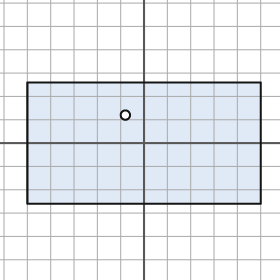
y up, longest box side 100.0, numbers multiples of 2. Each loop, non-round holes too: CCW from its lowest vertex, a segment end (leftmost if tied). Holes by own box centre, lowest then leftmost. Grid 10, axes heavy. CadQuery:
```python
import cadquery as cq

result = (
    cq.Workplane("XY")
    .moveTo(-50.0, -26.0)
    .lineTo(50.0, -26.0)
    .lineTo(50.0, 26.0)
    .lineTo(-50.0, 26.0)
    .close()
    .moveTo(-8.0, 12.0)
    .circle(2.0)
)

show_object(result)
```